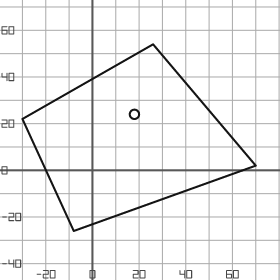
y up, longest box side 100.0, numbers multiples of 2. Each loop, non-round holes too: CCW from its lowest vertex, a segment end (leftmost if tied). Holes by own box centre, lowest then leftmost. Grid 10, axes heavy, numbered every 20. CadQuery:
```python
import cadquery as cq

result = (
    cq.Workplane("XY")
    .moveTo(-8.0, -26.0)
    .lineTo(70.0, 2.0)
    .lineTo(26.0, 54.0)
    .lineTo(-30.0, 22.0)
    .close()
    .moveTo(18.0, 24.0)
    .circle(2.0)
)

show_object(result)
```